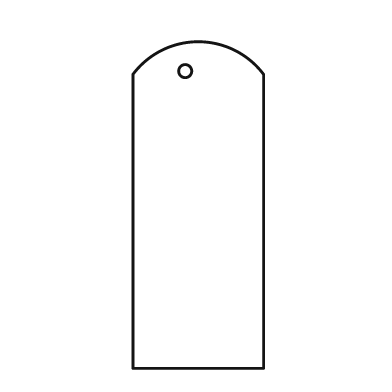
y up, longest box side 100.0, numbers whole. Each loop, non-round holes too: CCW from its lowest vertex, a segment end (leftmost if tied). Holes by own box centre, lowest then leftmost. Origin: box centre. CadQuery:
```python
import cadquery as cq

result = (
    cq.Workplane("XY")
    .moveTo(-20.0, -50.0)
    .lineTo(20.0, -50.0)
    .lineTo(20.0, 40.0)
    .threePointArc((0.0, 50.0), (-20.0, 40.0))
    .close()
    .moveTo(-4.0, 41.0)
    .circle(2.0)
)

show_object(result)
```